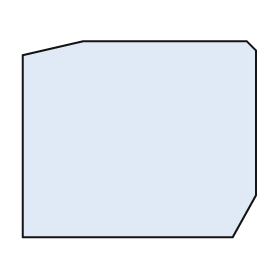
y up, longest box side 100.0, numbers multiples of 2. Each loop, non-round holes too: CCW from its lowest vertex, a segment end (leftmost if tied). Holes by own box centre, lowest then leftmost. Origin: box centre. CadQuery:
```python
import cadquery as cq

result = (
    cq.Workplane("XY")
    .moveTo(-50.0, -42.0)
    .lineTo(40.0, -42.0)
    .lineTo(50.0, -24.0)
    .lineTo(50.0, 38.0)
    .lineTo(46.0, 42.0)
    .lineTo(-24.0, 42.0)
    .lineTo(-50.0, 36.0)
    .close()
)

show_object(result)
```